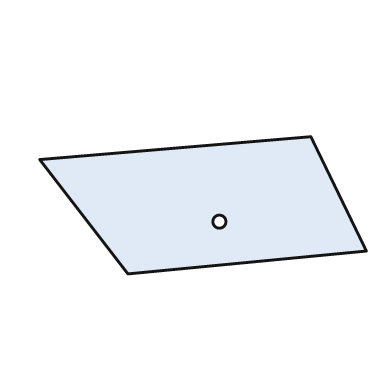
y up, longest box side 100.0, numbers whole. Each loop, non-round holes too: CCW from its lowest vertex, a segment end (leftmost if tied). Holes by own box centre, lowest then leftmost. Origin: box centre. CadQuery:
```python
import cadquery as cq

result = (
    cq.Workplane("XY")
    .moveTo(-23.0, -21.0)
    .lineTo(50.0, -14.0)
    .lineTo(33.0, 21.0)
    .lineTo(-50.0, 14.0)
    .close()
    .moveTo(5.0, -5.0)
    .circle(2.0)
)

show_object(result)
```